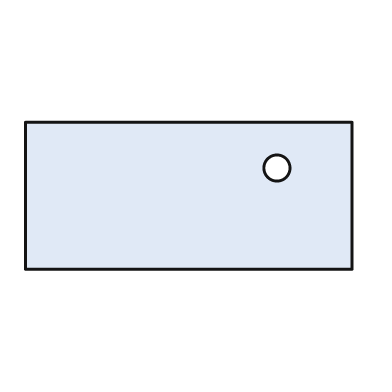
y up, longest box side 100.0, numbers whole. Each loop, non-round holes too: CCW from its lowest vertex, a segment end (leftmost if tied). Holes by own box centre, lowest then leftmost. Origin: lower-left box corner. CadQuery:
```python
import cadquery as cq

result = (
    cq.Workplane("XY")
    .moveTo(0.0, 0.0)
    .lineTo(100.0, 0.0)
    .lineTo(100.0, 45.0)
    .lineTo(0.0, 45.0)
    .close()
    .moveTo(77.0, 31.0)
    .circle(4.0)
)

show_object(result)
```